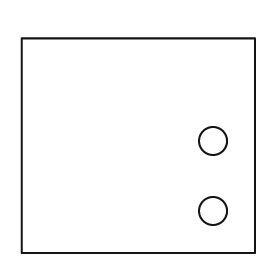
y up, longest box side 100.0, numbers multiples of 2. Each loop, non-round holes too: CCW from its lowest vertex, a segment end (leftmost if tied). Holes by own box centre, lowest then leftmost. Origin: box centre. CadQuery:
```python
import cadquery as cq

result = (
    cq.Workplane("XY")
    .moveTo(-50.0, -46.0)
    .lineTo(50.0, -46.0)
    .lineTo(50.0, 46.0)
    .lineTo(-50.0, 46.0)
    .close()
    .moveTo(32.0, -28.0)
    .circle(6.0)
    .moveTo(32.0, 2.0)
    .circle(6.0)
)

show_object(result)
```